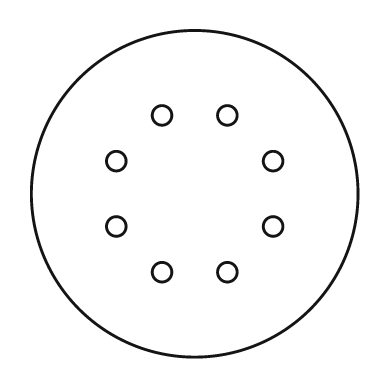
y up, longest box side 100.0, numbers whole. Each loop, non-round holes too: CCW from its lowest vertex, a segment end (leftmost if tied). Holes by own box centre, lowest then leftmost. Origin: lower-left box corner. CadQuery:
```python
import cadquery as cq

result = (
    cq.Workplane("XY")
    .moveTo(50.0, 50.0)
    .circle(50.0)
    .moveTo(40.0, 26.0)
    .circle(3.0)
    .moveTo(60.0, 26.0)
    .circle(3.0)
    .moveTo(26.0, 40.0)
    .circle(3.0)
    .moveTo(74.0, 40.0)
    .circle(3.0)
    .moveTo(26.0, 60.0)
    .circle(3.0)
    .moveTo(74.0, 60.0)
    .circle(3.0)
    .moveTo(40.0, 74.0)
    .circle(3.0)
    .moveTo(60.0, 74.0)
    .circle(3.0)
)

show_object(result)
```